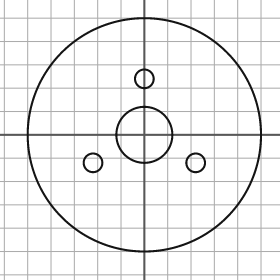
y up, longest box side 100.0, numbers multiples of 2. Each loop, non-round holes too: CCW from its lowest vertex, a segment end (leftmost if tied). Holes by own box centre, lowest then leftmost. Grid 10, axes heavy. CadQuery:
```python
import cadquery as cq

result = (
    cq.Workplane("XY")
    .moveTo(0.0, 0.0)
    .circle(50.0)
    .moveTo(-22.0, -12.0)
    .circle(4.0)
    .moveTo(22.0, -12.0)
    .circle(4.0)
    .moveTo(0.0, 0.0)
    .circle(12.0)
    .moveTo(0.0, 24.0)
    .circle(4.0)
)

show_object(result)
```